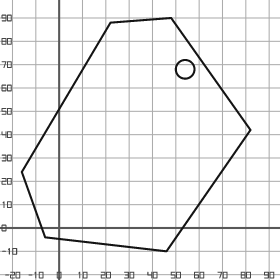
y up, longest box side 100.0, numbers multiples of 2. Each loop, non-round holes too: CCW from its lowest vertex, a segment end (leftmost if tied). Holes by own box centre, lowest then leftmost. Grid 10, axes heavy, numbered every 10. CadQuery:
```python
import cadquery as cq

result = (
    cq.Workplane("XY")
    .moveTo(46.0, -10.0)
    .lineTo(82.0, 42.0)
    .lineTo(48.0, 90.0)
    .lineTo(22.0, 88.0)
    .lineTo(-16.0, 24.0)
    .lineTo(-6.0, -4.0)
    .close()
    .moveTo(54.0, 68.0)
    .circle(4.0)
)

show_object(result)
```